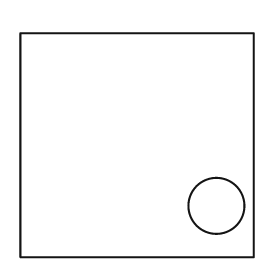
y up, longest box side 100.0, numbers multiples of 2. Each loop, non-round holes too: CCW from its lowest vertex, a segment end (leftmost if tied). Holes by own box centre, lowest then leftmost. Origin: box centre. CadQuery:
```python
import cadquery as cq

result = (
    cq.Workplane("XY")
    .moveTo(-50.0, -48.0)
    .lineTo(50.0, -48.0)
    .lineTo(50.0, 48.0)
    .lineTo(-50.0, 48.0)
    .close()
    .moveTo(34.0, -26.0)
    .circle(12.0)
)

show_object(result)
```